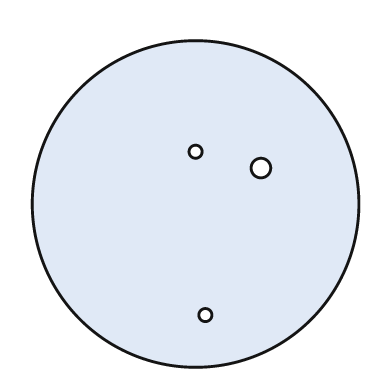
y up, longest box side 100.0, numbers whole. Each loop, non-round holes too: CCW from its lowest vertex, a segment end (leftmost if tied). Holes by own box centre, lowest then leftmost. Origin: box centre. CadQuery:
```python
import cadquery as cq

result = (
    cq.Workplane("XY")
    .moveTo(0.0, 0.0)
    .circle(50.0)
    .moveTo(3.0, -34.0)
    .circle(2.0)
    .moveTo(20.0, 11.0)
    .circle(3.0)
    .moveTo(0.0, 16.0)
    .circle(2.0)
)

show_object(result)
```